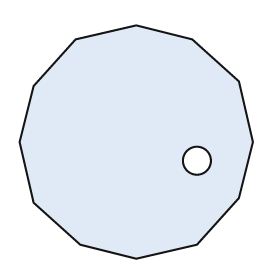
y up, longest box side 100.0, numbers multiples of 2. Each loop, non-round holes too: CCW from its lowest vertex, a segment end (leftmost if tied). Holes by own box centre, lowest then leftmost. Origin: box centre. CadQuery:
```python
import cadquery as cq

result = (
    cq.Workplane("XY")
    .moveTo(0.0, -50.0)
    .lineTo(26.0, -44.0)
    .lineTo(44.0, -24.0)
    .lineTo(50.0, 0.0)
    .lineTo(44.0, 26.0)
    .lineTo(24.0, 44.0)
    .lineTo(0.0, 50.0)
    .lineTo(-26.0, 44.0)
    .lineTo(-44.0, 24.0)
    .lineTo(-50.0, 0.0)
    .lineTo(-44.0, -26.0)
    .lineTo(-24.0, -44.0)
    .close()
    .moveTo(26.0, -8.0)
    .circle(6.0)
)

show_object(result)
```